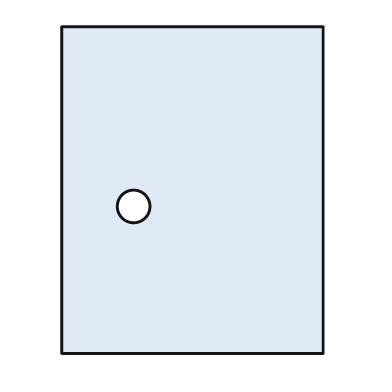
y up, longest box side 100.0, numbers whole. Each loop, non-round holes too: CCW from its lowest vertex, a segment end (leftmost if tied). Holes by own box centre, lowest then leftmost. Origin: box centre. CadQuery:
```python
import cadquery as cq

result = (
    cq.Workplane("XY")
    .moveTo(-40.0, -50.0)
    .lineTo(40.0, -50.0)
    .lineTo(40.0, 50.0)
    .lineTo(-40.0, 50.0)
    .close()
    .moveTo(-18.0, -5.0)
    .circle(5.0)
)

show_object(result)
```